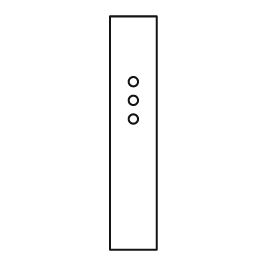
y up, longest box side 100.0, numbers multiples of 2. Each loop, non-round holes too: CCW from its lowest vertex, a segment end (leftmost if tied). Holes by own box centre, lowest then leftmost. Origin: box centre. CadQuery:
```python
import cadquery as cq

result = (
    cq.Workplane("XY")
    .moveTo(-10.0, -50.0)
    .lineTo(10.0, -50.0)
    .lineTo(10.0, 50.0)
    .lineTo(-10.0, 50.0)
    .close()
    .moveTo(0.0, 6.0)
    .circle(2.0)
    .moveTo(0.0, 14.0)
    .circle(2.0)
    .moveTo(0.0, 22.0)
    .circle(2.0)
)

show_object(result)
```